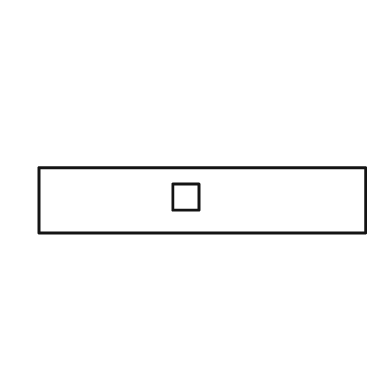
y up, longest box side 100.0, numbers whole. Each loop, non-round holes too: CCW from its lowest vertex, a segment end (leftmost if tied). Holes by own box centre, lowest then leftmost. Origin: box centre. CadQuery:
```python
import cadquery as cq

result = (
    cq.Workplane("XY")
    .moveTo(-50.0, -10.0)
    .lineTo(50.0, -10.0)
    .lineTo(50.0, 10.0)
    .lineTo(-50.0, 10.0)
    .close()
    .moveTo(-9.0, -3.0)
    .lineTo(-1.0, -3.0)
    .lineTo(-1.0, 5.0)
    .lineTo(-9.0, 5.0)
    .close()
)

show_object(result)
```